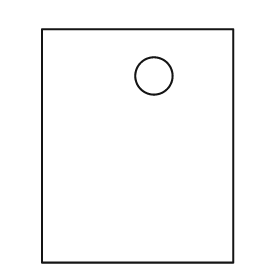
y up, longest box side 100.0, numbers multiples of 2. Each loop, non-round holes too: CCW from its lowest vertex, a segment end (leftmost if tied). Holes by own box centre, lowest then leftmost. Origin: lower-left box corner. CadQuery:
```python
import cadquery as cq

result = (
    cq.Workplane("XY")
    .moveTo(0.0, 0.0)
    .lineTo(82.0, 0.0)
    .lineTo(82.0, 100.0)
    .lineTo(0.0, 100.0)
    .close()
    .moveTo(48.0, 80.0)
    .circle(8.0)
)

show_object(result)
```